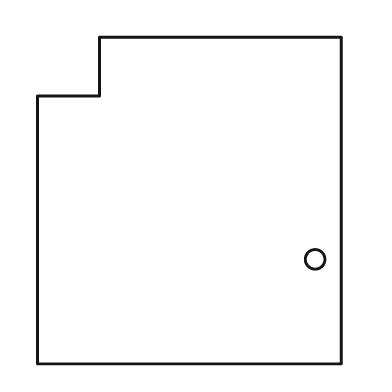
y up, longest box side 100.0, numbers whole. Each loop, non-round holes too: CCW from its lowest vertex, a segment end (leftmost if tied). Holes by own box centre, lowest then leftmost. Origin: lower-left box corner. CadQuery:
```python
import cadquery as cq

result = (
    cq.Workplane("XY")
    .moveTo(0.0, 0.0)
    .lineTo(93.0, 0.0)
    .lineTo(93.0, 100.0)
    .lineTo(19.0, 100.0)
    .lineTo(19.0, 82.0)
    .lineTo(0.0, 82.0)
    .close()
    .moveTo(85.0, 32.0)
    .circle(3.0)
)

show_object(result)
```